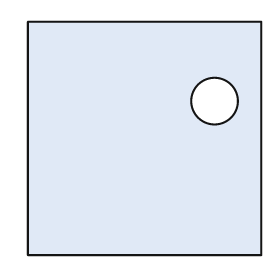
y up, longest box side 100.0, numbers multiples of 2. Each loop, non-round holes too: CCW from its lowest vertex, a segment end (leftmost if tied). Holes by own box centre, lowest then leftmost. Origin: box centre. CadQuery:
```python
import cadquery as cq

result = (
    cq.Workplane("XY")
    .moveTo(-50.0, -50.0)
    .lineTo(50.0, -50.0)
    .lineTo(50.0, 50.0)
    .lineTo(-50.0, 50.0)
    .close()
    .moveTo(30.0, 16.0)
    .circle(10.0)
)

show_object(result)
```